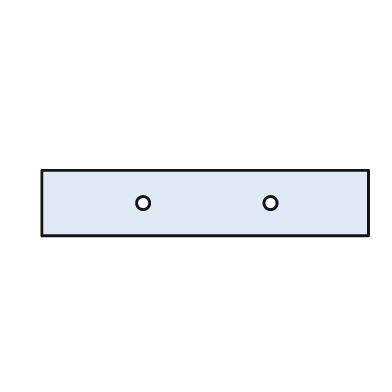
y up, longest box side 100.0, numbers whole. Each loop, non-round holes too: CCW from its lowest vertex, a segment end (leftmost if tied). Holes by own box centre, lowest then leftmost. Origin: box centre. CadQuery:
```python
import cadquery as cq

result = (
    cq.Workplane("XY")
    .moveTo(-50.0, -10.0)
    .lineTo(50.0, -10.0)
    .lineTo(50.0, 10.0)
    .lineTo(-50.0, 10.0)
    .close()
    .moveTo(-19.0, 0.0)
    .circle(2.0)
    .moveTo(20.0, 0.0)
    .circle(2.0)
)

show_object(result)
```